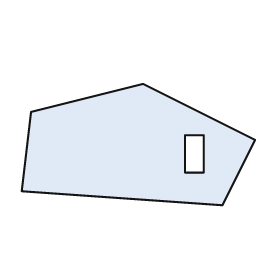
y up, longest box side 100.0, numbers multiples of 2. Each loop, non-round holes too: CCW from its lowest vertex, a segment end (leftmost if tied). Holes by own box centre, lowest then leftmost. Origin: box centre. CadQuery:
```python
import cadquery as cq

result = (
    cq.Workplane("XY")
    .moveTo(36.0, -26.0)
    .lineTo(50.0, 2.0)
    .lineTo(2.0, 26.0)
    .lineTo(-46.0, 14.0)
    .lineTo(-50.0, -20.0)
    .close()
    .moveTo(20.0, -12.0)
    .lineTo(28.0, -12.0)
    .lineTo(28.0, 4.0)
    .lineTo(20.0, 4.0)
    .close()
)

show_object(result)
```